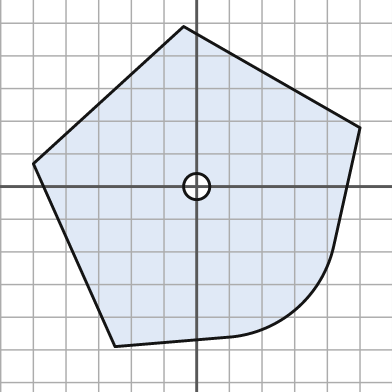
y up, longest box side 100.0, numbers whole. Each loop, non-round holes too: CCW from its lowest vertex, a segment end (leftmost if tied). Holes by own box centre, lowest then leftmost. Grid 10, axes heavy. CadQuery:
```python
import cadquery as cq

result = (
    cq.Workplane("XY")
    .moveTo(-25.0, -49.0)
    .lineTo(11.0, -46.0)
    .threePointArc((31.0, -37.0), (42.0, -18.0))
    .lineTo(50.0, 18.0)
    .lineTo(-4.0, 49.0)
    .lineTo(-50.0, 7.0)
    .close()
    .moveTo(0.0, 0.0)
    .circle(4.0)
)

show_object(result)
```